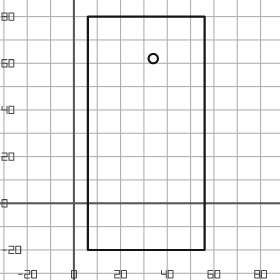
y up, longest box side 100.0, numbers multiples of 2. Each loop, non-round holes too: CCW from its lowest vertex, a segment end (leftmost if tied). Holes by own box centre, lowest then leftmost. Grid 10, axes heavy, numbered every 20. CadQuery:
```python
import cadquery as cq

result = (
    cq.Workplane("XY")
    .moveTo(6.0, -20.0)
    .lineTo(56.0, -20.0)
    .lineTo(56.0, 80.0)
    .lineTo(6.0, 80.0)
    .close()
    .moveTo(34.0, 62.0)
    .circle(2.0)
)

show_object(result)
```